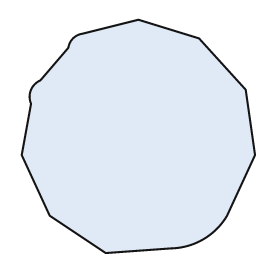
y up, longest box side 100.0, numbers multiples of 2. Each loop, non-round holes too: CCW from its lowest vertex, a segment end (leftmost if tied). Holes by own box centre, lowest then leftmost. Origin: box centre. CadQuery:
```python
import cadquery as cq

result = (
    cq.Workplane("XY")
    .moveTo(-14.0, -50.0)
    .lineTo(14.0, -48.0)
    .threePointArc((28.0, -44.0), (38.0, -34.0))
    .lineTo(50.0, -8.0)
    .lineTo(46.0, 20.0)
    .lineTo(26.0, 42.0)
    .lineTo(0.0, 50.0)
    .lineTo(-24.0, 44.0)
    .threePointArc((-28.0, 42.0), (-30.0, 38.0))
    .lineTo(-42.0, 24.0)
    .threePointArc((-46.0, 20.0), (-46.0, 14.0))
    .lineTo(-50.0, -8.0)
    .lineTo(-38.0, -34.0)
    .close()
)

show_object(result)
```